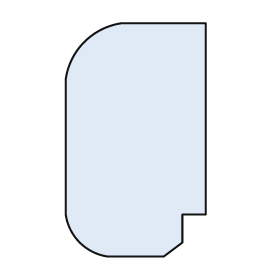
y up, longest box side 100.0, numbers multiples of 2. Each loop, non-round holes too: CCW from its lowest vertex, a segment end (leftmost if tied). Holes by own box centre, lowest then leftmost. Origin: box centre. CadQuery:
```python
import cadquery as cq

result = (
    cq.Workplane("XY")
    .moveTo(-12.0, -50.0)
    .lineTo(12.0, -50.0)
    .lineTo(20.0, -44.0)
    .lineTo(20.0, -32.0)
    .lineTo(30.0, -32.0)
    .lineTo(30.0, 50.0)
    .lineTo(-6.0, 50.0)
    .threePointArc((-22.0, 42.0), (-30.0, 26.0))
    .lineTo(-30.0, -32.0)
    .threePointArc((-24.0, -44.0), (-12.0, -50.0))
    .close()
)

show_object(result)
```